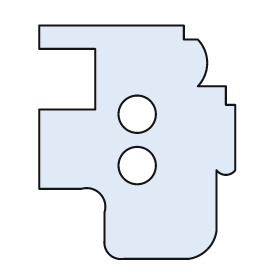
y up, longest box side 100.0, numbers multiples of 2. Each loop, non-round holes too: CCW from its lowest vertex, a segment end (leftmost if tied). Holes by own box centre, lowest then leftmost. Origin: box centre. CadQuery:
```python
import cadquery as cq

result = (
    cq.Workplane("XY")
    .moveTo(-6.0, -50.0)
    .lineTo(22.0, -50.0)
    .threePointArc((30.0, -46.0), (34.0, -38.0))
    .lineTo(34.0, -12.0)
    .threePointArc((38.0, -14.0), (42.0, -12.0))
    .lineTo(42.0, 16.0)
    .lineTo(38.0, 16.0)
    .lineTo(38.0, 24.0)
    .lineTo(26.0, 24.0)
    .threePointArc((30.0, 34.0), (26.0, 44.0))
    .lineTo(20.0, 44.0)
    .lineTo(20.0, 50.0)
    .lineTo(-42.0, 50.0)
    .lineTo(-42.0, 40.0)
    .lineTo(-18.0, 40.0)
    .lineTo(-18.0, 14.0)
    .lineTo(-42.0, 14.0)
    .lineTo(-42.0, -20.0)
    .lineTo(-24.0, -20.0)
    .threePointArc((-16.0, -22.0), (-14.0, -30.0))
    .lineTo(-14.0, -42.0)
    .threePointArc((-12.0, -48.0), (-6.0, -50.0))
    .close()
    .moveTo(0.0, -10.0)
    .circle(8.0)
    .moveTo(0.0, 12.0)
    .circle(8.0)
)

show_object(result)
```